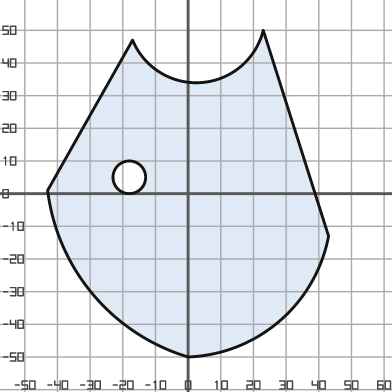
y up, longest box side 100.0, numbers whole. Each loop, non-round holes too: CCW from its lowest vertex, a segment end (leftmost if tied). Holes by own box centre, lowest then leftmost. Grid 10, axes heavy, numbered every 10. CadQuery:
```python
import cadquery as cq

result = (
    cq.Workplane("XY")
    .moveTo(0.0, -50.0)
    .threePointArc((28.0, -39.0), (43.0, -13.0))
    .lineTo(23.0, 50.0)
    .threePointArc((4.0, 34.0), (-17.0, 47.0))
    .lineTo(-43.0, 1.0)
    .threePointArc((-29.0, -31.0), (0.0, -50.0))
    .close()
    .moveTo(-18.0, 5.0)
    .circle(5.0)
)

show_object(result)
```